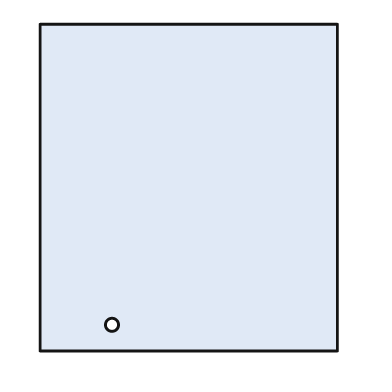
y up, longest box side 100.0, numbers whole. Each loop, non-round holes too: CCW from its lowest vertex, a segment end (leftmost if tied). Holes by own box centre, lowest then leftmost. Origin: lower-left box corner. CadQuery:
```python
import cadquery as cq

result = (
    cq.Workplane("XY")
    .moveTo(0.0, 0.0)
    .lineTo(91.0, 0.0)
    .lineTo(91.0, 100.0)
    .lineTo(0.0, 100.0)
    .close()
    .moveTo(22.0, 8.0)
    .circle(2.0)
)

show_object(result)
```